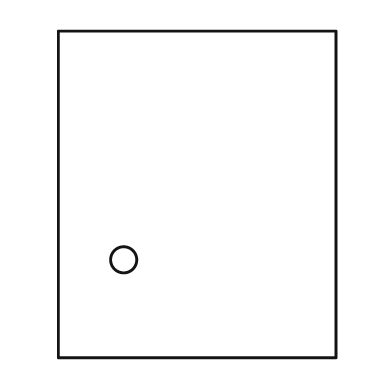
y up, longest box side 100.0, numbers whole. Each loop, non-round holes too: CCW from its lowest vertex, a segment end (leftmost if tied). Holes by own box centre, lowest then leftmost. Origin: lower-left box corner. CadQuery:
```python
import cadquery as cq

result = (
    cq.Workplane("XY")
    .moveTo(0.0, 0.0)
    .lineTo(85.0, 0.0)
    .lineTo(85.0, 100.0)
    .lineTo(0.0, 100.0)
    .close()
    .moveTo(20.0, 30.0)
    .circle(4.0)
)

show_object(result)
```